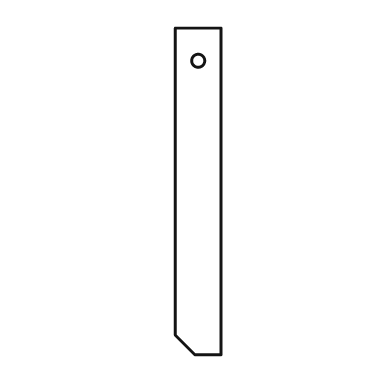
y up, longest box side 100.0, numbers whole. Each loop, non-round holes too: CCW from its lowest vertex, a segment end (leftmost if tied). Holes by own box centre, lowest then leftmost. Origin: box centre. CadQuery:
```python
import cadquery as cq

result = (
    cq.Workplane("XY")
    .moveTo(-1.0, -50.0)
    .lineTo(7.0, -50.0)
    .lineTo(7.0, 50.0)
    .lineTo(-7.0, 50.0)
    .lineTo(-7.0, -44.0)
    .close()
    .moveTo(0.0, 40.0)
    .circle(2.0)
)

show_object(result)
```